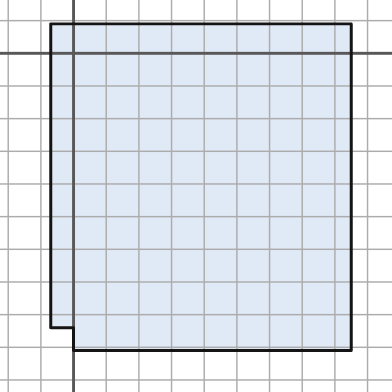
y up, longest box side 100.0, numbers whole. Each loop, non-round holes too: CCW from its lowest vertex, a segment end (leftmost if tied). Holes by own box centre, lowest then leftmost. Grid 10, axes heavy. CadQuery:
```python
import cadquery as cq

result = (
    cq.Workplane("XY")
    .moveTo(0.0, -91.0)
    .lineTo(85.0, -91.0)
    .lineTo(85.0, 9.0)
    .lineTo(-7.0, 9.0)
    .lineTo(-7.0, -84.0)
    .lineTo(0.0, -84.0)
    .close()
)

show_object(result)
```